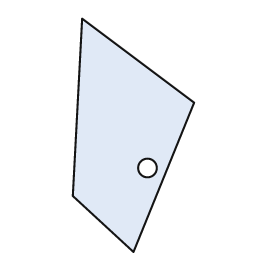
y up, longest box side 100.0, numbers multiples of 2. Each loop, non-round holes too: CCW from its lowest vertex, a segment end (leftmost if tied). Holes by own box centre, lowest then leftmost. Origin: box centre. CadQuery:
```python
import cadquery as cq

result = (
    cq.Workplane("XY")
    .moveTo(0.0, -50.0)
    .lineTo(26.0, 14.0)
    .lineTo(-22.0, 50.0)
    .lineTo(-26.0, -26.0)
    .close()
    .moveTo(6.0, -14.0)
    .circle(4.0)
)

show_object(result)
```